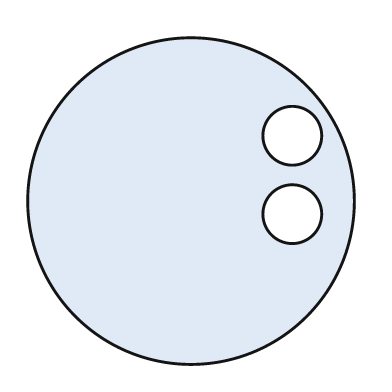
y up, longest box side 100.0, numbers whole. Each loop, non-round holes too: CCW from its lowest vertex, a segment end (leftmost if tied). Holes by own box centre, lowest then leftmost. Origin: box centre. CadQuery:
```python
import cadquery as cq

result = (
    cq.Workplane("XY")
    .moveTo(0.0, 0.0)
    .circle(50.0)
    .moveTo(31.0, -4.0)
    .circle(9.0)
    .moveTo(31.0, 20.0)
    .circle(9.0)
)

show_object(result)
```